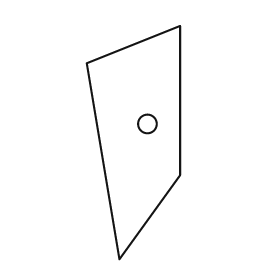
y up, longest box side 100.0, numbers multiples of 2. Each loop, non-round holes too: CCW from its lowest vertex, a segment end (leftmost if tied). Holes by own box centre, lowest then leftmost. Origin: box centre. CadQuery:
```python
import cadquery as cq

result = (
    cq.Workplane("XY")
    .moveTo(-6.0, -50.0)
    .lineTo(20.0, -14.0)
    .lineTo(20.0, 50.0)
    .lineTo(-20.0, 34.0)
    .close()
    .moveTo(6.0, 8.0)
    .circle(4.0)
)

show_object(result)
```